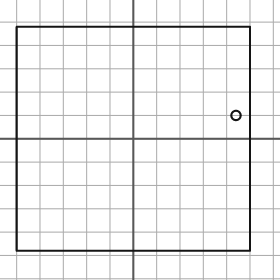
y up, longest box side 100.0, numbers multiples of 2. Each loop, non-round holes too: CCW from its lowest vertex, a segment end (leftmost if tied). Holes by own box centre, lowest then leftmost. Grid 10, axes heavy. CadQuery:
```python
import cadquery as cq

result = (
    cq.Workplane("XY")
    .moveTo(-50.0, -48.0)
    .lineTo(50.0, -48.0)
    .lineTo(50.0, 48.0)
    .lineTo(-50.0, 48.0)
    .close()
    .moveTo(44.0, 10.0)
    .circle(2.0)
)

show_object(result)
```